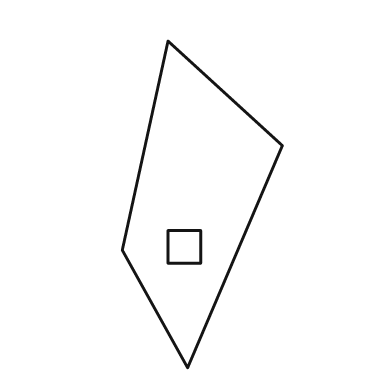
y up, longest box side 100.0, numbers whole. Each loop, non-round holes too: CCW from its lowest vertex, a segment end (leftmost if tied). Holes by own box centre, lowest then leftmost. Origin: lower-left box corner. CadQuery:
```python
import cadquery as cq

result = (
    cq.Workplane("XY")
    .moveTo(20.0, 0.0)
    .lineTo(49.0, 68.0)
    .lineTo(14.0, 100.0)
    .lineTo(0.0, 36.0)
    .close()
    .moveTo(14.0, 32.0)
    .lineTo(24.0, 32.0)
    .lineTo(24.0, 42.0)
    .lineTo(14.0, 42.0)
    .close()
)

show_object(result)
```